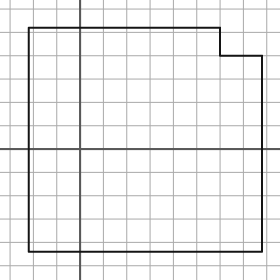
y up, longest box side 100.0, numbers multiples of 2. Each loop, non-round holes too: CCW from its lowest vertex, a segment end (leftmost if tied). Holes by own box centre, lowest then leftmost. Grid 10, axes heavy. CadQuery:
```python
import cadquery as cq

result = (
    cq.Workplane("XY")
    .moveTo(-22.0, -44.0)
    .lineTo(78.0, -44.0)
    .lineTo(78.0, 40.0)
    .lineTo(60.0, 40.0)
    .lineTo(60.0, 52.0)
    .lineTo(-22.0, 52.0)
    .close()
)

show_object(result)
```